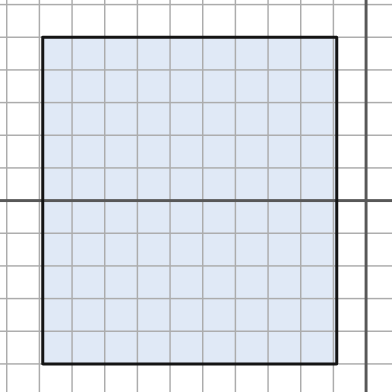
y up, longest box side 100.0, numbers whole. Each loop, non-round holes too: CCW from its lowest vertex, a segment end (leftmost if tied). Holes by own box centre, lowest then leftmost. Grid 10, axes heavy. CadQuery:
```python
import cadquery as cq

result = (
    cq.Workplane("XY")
    .moveTo(-99.0, -50.0)
    .lineTo(-9.0, -50.0)
    .lineTo(-9.0, 50.0)
    .lineTo(-99.0, 50.0)
    .close()
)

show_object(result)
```